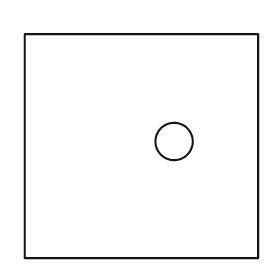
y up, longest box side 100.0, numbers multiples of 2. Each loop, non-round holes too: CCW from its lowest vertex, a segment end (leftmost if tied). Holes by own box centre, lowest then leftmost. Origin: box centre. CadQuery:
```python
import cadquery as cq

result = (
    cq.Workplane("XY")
    .moveTo(-50.0, -48.0)
    .lineTo(50.0, -48.0)
    .lineTo(50.0, 48.0)
    .lineTo(-50.0, 48.0)
    .close()
    .moveTo(14.0, 2.0)
    .circle(8.0)
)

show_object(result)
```